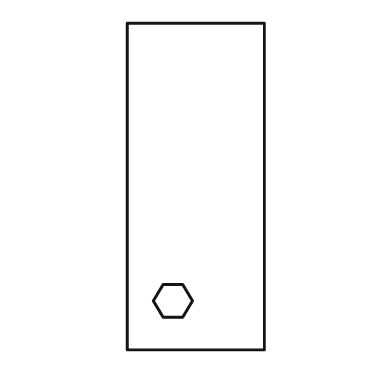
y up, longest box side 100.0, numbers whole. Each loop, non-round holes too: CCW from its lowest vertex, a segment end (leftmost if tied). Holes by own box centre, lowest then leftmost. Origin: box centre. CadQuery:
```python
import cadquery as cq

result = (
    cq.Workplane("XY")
    .moveTo(-21.0, -50.0)
    .lineTo(21.0, -50.0)
    .lineTo(21.0, 50.0)
    .lineTo(-21.0, 50.0)
    .close()
    .moveTo(-10.0, -40.0)
    .lineTo(-4.0, -40.0)
    .lineTo(-1.0, -35.0)
    .lineTo(-4.0, -30.0)
    .lineTo(-10.0, -30.0)
    .lineTo(-13.0, -35.0)
    .close()
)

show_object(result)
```